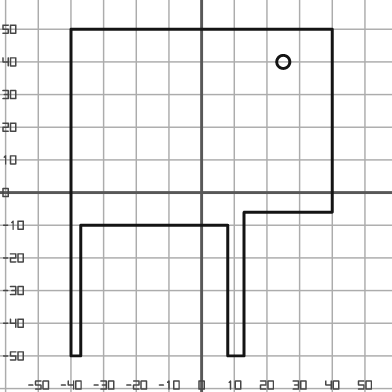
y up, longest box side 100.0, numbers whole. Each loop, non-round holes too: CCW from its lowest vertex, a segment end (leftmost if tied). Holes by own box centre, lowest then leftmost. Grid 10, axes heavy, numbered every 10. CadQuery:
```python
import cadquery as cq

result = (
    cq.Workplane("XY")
    .moveTo(-40.0, -50.0)
    .lineTo(-37.0, -50.0)
    .lineTo(-37.0, -10.0)
    .lineTo(8.0, -10.0)
    .lineTo(8.0, -50.0)
    .lineTo(13.0, -50.0)
    .lineTo(13.0, -6.0)
    .lineTo(40.0, -6.0)
    .lineTo(40.0, 50.0)
    .lineTo(-40.0, 50.0)
    .close()
    .moveTo(25.0, 40.0)
    .circle(2.0)
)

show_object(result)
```